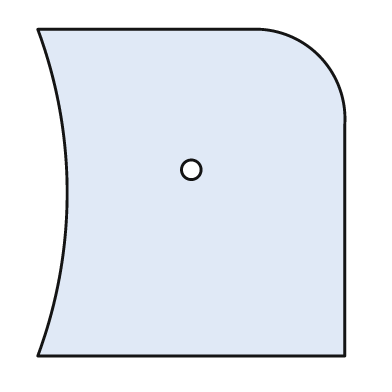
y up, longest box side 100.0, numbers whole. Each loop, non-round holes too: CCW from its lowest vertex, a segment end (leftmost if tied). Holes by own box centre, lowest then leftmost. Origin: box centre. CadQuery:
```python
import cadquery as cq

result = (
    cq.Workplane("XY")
    .moveTo(-47.0, -50.0)
    .lineTo(47.0, -50.0)
    .lineTo(47.0, 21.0)
    .threePointArc((39.0, 42.0), (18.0, 50.0))
    .lineTo(-47.0, 50.0)
    .threePointArc((-38.0, 0.0), (-47.0, -50.0))
    .close()
    .moveTo(0.0, 7.0)
    .circle(3.0)
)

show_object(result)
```